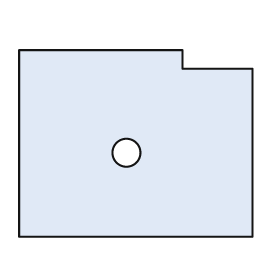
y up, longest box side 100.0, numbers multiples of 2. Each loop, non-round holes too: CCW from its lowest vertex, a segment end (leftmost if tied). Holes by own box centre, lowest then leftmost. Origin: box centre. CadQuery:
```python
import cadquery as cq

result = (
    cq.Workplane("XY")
    .moveTo(-50.0, -40.0)
    .lineTo(50.0, -40.0)
    .lineTo(50.0, 32.0)
    .lineTo(20.0, 32.0)
    .lineTo(20.0, 40.0)
    .lineTo(-50.0, 40.0)
    .close()
    .moveTo(-4.0, -4.0)
    .circle(6.0)
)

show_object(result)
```